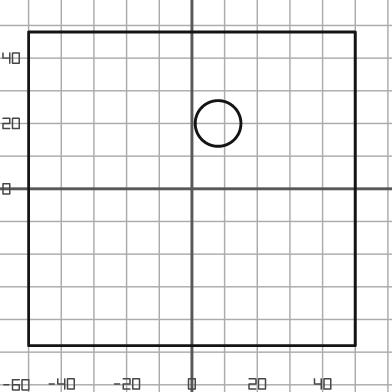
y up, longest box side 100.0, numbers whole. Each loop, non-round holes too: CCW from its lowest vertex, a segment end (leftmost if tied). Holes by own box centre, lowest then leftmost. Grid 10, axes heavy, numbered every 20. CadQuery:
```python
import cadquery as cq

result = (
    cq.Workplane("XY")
    .moveTo(-50.0, -48.0)
    .lineTo(50.0, -48.0)
    .lineTo(50.0, 48.0)
    .lineTo(-50.0, 48.0)
    .close()
    .moveTo(8.0, 20.0)
    .circle(7.0)
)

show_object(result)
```